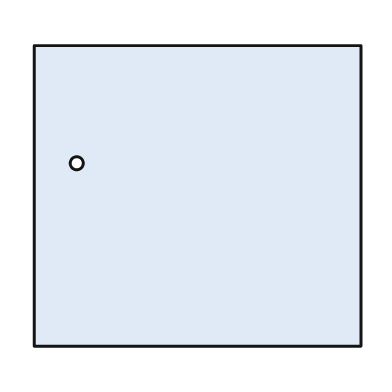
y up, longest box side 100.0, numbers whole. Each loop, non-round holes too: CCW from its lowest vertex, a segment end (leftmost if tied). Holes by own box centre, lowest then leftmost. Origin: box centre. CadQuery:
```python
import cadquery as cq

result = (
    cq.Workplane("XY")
    .moveTo(-50.0, -46.0)
    .lineTo(50.0, -46.0)
    .lineTo(50.0, 46.0)
    .lineTo(-50.0, 46.0)
    .close()
    .moveTo(-37.0, 10.0)
    .circle(2.0)
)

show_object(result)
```